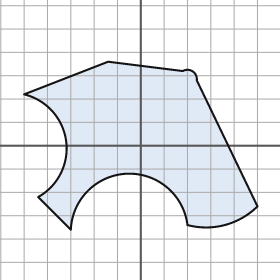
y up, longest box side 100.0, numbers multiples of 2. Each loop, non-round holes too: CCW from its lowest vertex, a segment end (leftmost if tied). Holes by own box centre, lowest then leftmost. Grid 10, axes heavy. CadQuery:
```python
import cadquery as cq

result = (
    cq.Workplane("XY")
    .moveTo(-30.0, -36.0)
    .threePointArc((-6.0, -12.0), (20.0, -34.0))
    .threePointArc((36.0, -34.0), (50.0, -26.0))
    .lineTo(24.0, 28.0)
    .threePointArc((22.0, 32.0), (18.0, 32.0))
    .lineTo(-14.0, 36.0)
    .lineTo(-50.0, 22.0)
    .threePointArc((-32.0, 2.0), (-44.0, -22.0))
    .close()
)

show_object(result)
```